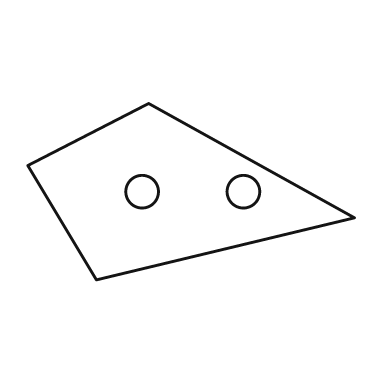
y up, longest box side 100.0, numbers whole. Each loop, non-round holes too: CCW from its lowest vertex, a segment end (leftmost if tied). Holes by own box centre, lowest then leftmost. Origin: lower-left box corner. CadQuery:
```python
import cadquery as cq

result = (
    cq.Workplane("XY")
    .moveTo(21.0, 0.0)
    .lineTo(100.0, 19.0)
    .lineTo(37.0, 54.0)
    .lineTo(0.0, 35.0)
    .close()
    .moveTo(35.0, 27.0)
    .circle(5.0)
    .moveTo(66.0, 27.0)
    .circle(5.0)
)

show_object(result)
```